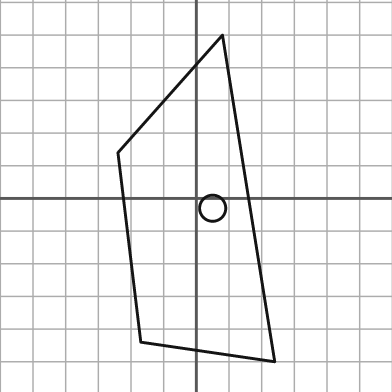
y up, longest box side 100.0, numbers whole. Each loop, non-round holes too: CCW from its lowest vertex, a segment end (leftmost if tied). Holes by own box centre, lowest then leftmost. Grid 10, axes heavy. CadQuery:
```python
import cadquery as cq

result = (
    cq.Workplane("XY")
    .moveTo(24.0, -50.0)
    .lineTo(8.0, 50.0)
    .lineTo(-24.0, 14.0)
    .lineTo(-17.0, -44.0)
    .close()
    .moveTo(5.0, -3.0)
    .circle(4.0)
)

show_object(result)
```